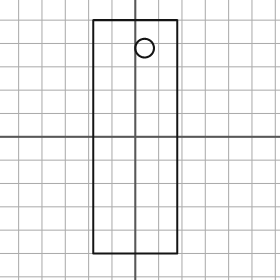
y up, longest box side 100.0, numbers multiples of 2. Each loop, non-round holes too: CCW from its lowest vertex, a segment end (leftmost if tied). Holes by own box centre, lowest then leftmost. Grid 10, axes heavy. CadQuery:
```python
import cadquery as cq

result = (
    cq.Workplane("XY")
    .moveTo(-18.0, -50.0)
    .lineTo(18.0, -50.0)
    .lineTo(18.0, 50.0)
    .lineTo(-18.0, 50.0)
    .close()
    .moveTo(4.0, 38.0)
    .circle(4.0)
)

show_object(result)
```